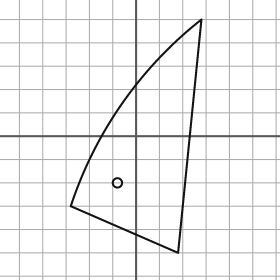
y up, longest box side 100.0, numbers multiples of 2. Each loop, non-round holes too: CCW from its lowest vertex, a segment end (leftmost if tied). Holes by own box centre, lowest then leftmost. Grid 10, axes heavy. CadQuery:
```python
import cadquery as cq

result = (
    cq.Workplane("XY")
    .moveTo(18.0, -50.0)
    .lineTo(28.0, 50.0)
    .threePointArc((-6.0, 14.0), (-28.0, -30.0))
    .close()
    .moveTo(-8.0, -20.0)
    .circle(2.0)
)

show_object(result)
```